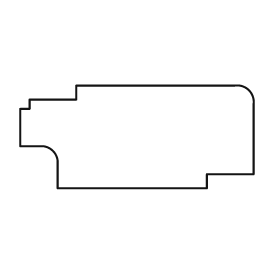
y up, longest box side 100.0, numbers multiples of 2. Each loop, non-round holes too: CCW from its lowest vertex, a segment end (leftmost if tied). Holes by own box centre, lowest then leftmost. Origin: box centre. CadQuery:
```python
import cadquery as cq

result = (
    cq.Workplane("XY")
    .moveTo(-34.0, -22.0)
    .lineTo(30.0, -22.0)
    .lineTo(30.0, -16.0)
    .lineTo(50.0, -16.0)
    .lineTo(50.0, 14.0)
    .threePointArc((48.0, 20.0), (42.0, 22.0))
    .lineTo(-26.0, 22.0)
    .lineTo(-26.0, 16.0)
    .lineTo(-46.0, 16.0)
    .lineTo(-46.0, 12.0)
    .lineTo(-50.0, 12.0)
    .lineTo(-50.0, -4.0)
    .lineTo(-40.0, -4.0)
    .threePointArc((-36.0, -6.0), (-34.0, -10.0))
    .close()
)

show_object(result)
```